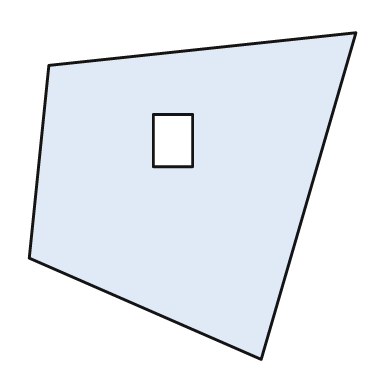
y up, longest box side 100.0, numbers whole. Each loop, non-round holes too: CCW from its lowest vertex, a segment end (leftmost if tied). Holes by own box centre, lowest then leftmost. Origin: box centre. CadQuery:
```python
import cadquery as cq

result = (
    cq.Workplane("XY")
    .moveTo(21.0, -50.0)
    .lineTo(50.0, 50.0)
    .lineTo(-44.0, 40.0)
    .lineTo(-50.0, -19.0)
    .close()
    .moveTo(-12.0, 9.0)
    .lineTo(0.0, 9.0)
    .lineTo(0.0, 25.0)
    .lineTo(-12.0, 25.0)
    .close()
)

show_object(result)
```